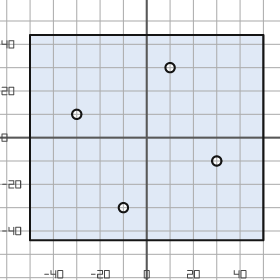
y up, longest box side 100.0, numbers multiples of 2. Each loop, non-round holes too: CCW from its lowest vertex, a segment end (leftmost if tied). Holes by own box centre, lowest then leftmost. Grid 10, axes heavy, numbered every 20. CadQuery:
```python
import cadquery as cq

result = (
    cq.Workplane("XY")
    .moveTo(-50.0, -44.0)
    .lineTo(50.0, -44.0)
    .lineTo(50.0, 44.0)
    .lineTo(-50.0, 44.0)
    .close()
    .moveTo(-10.0, -30.0)
    .circle(2.0)
    .moveTo(30.0, -10.0)
    .circle(2.0)
    .moveTo(-30.0, 10.0)
    .circle(2.0)
    .moveTo(10.0, 30.0)
    .circle(2.0)
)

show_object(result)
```